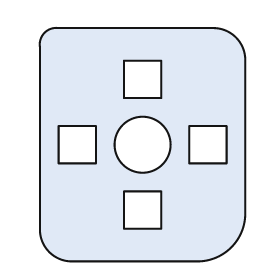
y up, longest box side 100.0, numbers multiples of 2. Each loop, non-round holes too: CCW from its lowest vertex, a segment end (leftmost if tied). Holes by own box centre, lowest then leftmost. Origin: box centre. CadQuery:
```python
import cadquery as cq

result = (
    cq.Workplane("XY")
    .moveTo(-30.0, -50.0)
    .lineTo(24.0, -50.0)
    .threePointArc((38.0, -44.0), (44.0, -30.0))
    .lineTo(44.0, 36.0)
    .threePointArc((40.0, 46.0), (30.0, 50.0))
    .lineTo(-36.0, 50.0)
    .threePointArc((-42.0, 48.0), (-44.0, 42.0))
    .lineTo(-44.0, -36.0)
    .threePointArc((-40.0, -46.0), (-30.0, -50.0))
    .close()
    .moveTo(-8.0, -36.0)
    .lineTo(8.0, -36.0)
    .lineTo(8.0, -20.0)
    .lineTo(-8.0, -20.0)
    .close()
    .moveTo(-36.0, -8.0)
    .lineTo(-20.0, -8.0)
    .lineTo(-20.0, 8.0)
    .lineTo(-36.0, 8.0)
    .close()
    .moveTo(0.0, 0.0)
    .circle(12.0)
    .moveTo(20.0, -8.0)
    .lineTo(36.0, -8.0)
    .lineTo(36.0, 8.0)
    .lineTo(20.0, 8.0)
    .close()
    .moveTo(-8.0, 20.0)
    .lineTo(8.0, 20.0)
    .lineTo(8.0, 36.0)
    .lineTo(-8.0, 36.0)
    .close()
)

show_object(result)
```